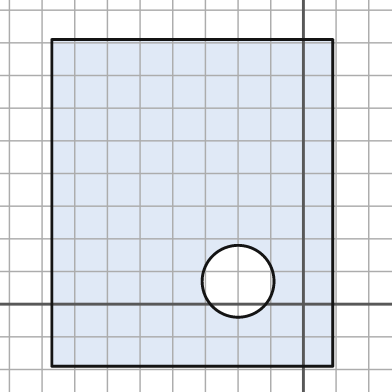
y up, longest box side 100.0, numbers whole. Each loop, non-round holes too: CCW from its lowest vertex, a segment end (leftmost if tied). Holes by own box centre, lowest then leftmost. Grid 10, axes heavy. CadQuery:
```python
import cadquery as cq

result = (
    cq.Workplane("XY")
    .moveTo(-77.0, -19.0)
    .lineTo(9.0, -19.0)
    .lineTo(9.0, 81.0)
    .lineTo(-77.0, 81.0)
    .close()
    .moveTo(-20.0, 7.0)
    .circle(11.0)
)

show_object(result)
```